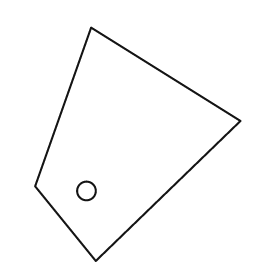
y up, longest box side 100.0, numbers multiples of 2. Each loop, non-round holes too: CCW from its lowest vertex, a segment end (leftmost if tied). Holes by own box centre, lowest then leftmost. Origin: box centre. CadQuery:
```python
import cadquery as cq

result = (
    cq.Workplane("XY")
    .moveTo(-18.0, -50.0)
    .lineTo(44.0, 10.0)
    .lineTo(-20.0, 50.0)
    .lineTo(-44.0, -18.0)
    .close()
    .moveTo(-22.0, -20.0)
    .circle(4.0)
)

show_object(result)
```